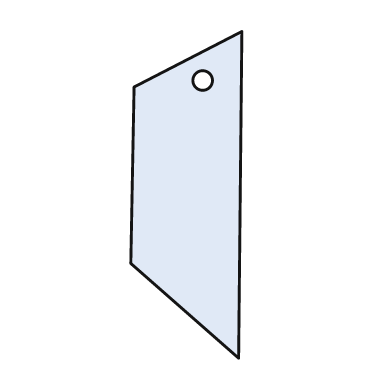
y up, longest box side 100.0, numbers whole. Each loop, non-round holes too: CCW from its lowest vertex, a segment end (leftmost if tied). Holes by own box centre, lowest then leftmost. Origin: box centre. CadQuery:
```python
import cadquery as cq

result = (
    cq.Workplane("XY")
    .moveTo(16.0, -50.0)
    .lineTo(17.0, 50.0)
    .lineTo(-16.0, 33.0)
    .lineTo(-17.0, -21.0)
    .close()
    .moveTo(5.0, 35.0)
    .circle(3.0)
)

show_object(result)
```